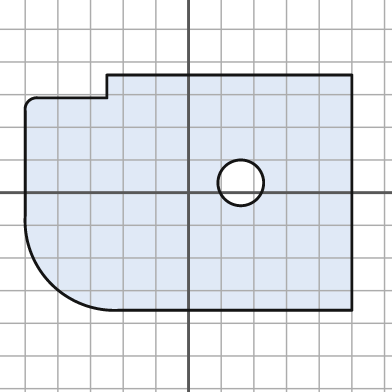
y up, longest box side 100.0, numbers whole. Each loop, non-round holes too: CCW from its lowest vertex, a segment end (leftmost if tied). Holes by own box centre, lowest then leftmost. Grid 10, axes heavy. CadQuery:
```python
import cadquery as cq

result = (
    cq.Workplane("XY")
    .moveTo(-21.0, -36.0)
    .lineTo(50.0, -36.0)
    .lineTo(50.0, 36.0)
    .lineTo(-25.0, 36.0)
    .lineTo(-25.0, 29.0)
    .lineTo(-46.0, 29.0)
    .threePointArc((-49.0, 28.0), (-50.0, 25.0))
    .lineTo(-50.0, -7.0)
    .threePointArc((-42.0, -28.0), (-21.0, -36.0))
    .close()
    .moveTo(16.0, 3.0)
    .circle(7.0)
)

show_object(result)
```